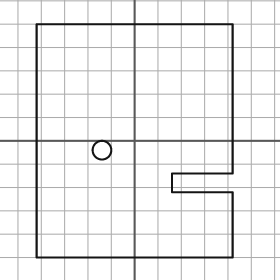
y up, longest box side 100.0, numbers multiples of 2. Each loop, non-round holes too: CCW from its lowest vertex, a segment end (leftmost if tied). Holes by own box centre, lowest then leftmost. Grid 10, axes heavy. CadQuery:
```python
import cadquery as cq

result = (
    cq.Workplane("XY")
    .moveTo(-42.0, -50.0)
    .lineTo(42.0, -50.0)
    .lineTo(42.0, -22.0)
    .lineTo(16.0, -22.0)
    .lineTo(16.0, -14.0)
    .lineTo(42.0, -14.0)
    .lineTo(42.0, 50.0)
    .lineTo(-42.0, 50.0)
    .close()
    .moveTo(-14.0, -4.0)
    .circle(4.0)
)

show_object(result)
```